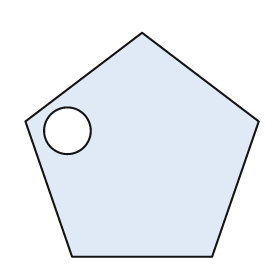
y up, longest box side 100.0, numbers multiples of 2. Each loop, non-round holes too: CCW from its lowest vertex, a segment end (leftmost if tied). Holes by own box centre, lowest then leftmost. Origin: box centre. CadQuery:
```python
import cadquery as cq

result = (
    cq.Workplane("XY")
    .moveTo(-30.0, -48.0)
    .lineTo(30.0, -48.0)
    .lineTo(50.0, 10.0)
    .lineTo(0.0, 48.0)
    .lineTo(-50.0, 10.0)
    .close()
    .moveTo(-32.0, 6.0)
    .circle(10.0)
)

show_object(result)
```